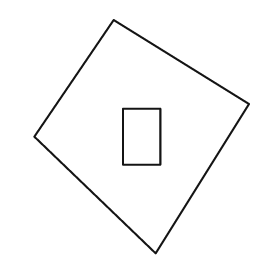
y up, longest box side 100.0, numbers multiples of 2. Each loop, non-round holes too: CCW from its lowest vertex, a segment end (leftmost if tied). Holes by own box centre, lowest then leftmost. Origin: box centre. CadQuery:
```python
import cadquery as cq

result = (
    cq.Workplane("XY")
    .moveTo(6.0, -50.0)
    .lineTo(46.0, 14.0)
    .lineTo(-12.0, 50.0)
    .lineTo(-46.0, 0.0)
    .close()
    .moveTo(-8.0, -12.0)
    .lineTo(8.0, -12.0)
    .lineTo(8.0, 12.0)
    .lineTo(-8.0, 12.0)
    .close()
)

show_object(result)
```